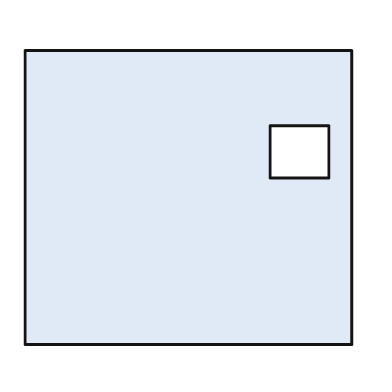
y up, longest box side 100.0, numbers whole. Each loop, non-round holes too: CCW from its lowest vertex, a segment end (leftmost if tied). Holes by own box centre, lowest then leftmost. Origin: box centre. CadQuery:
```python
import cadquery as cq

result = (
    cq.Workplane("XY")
    .moveTo(-50.0, -45.0)
    .lineTo(50.0, -45.0)
    .lineTo(50.0, 45.0)
    .lineTo(-50.0, 45.0)
    .close()
    .moveTo(25.0, 6.0)
    .lineTo(43.0, 6.0)
    .lineTo(43.0, 22.0)
    .lineTo(25.0, 22.0)
    .close()
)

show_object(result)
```